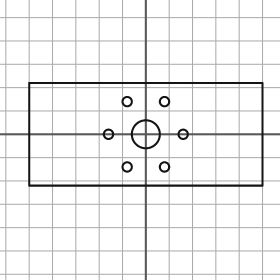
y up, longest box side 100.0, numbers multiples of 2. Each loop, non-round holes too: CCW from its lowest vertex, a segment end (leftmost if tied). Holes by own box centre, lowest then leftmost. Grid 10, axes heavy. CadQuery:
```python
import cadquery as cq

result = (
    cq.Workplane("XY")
    .moveTo(-50.0, -22.0)
    .lineTo(50.0, -22.0)
    .lineTo(50.0, 22.0)
    .lineTo(-50.0, 22.0)
    .close()
    .moveTo(-8.0, -14.0)
    .circle(2.0)
    .moveTo(8.0, -14.0)
    .circle(2.0)
    .moveTo(-16.0, 0.0)
    .circle(2.0)
    .moveTo(0.0, 0.0)
    .circle(6.0)
    .moveTo(16.0, 0.0)
    .circle(2.0)
    .moveTo(-8.0, 14.0)
    .circle(2.0)
    .moveTo(8.0, 14.0)
    .circle(2.0)
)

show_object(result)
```